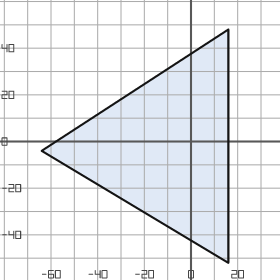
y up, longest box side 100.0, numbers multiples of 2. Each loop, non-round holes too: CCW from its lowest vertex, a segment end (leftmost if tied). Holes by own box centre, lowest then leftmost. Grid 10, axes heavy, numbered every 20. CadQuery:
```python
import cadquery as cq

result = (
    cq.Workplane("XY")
    .moveTo(16.0, -52.0)
    .lineTo(16.0, 48.0)
    .lineTo(-64.0, -4.0)
    .close()
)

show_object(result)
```